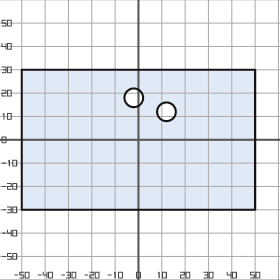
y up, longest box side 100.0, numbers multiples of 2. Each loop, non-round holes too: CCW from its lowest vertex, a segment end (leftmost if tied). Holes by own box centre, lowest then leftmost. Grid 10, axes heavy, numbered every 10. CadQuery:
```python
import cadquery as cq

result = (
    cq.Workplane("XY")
    .moveTo(-50.0, -30.0)
    .lineTo(50.0, -30.0)
    .lineTo(50.0, 30.0)
    .lineTo(-50.0, 30.0)
    .close()
    .moveTo(12.0, 12.0)
    .circle(4.0)
    .moveTo(-2.0, 18.0)
    .circle(4.0)
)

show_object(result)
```